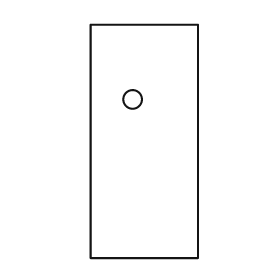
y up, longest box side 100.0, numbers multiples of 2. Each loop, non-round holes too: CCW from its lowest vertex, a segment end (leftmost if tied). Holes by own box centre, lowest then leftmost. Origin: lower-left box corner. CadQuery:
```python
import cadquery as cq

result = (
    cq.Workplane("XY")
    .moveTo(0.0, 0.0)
    .lineTo(46.0, 0.0)
    .lineTo(46.0, 100.0)
    .lineTo(0.0, 100.0)
    .close()
    .moveTo(18.0, 68.0)
    .circle(4.0)
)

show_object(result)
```